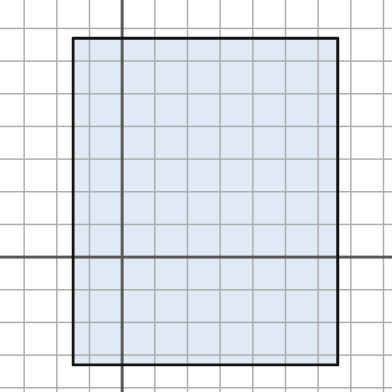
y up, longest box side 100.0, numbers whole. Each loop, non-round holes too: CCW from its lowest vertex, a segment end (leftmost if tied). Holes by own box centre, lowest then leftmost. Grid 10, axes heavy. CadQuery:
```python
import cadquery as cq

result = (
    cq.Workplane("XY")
    .moveTo(-15.0, -33.0)
    .lineTo(66.0, -33.0)
    .lineTo(66.0, 67.0)
    .lineTo(-15.0, 67.0)
    .close()
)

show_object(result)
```